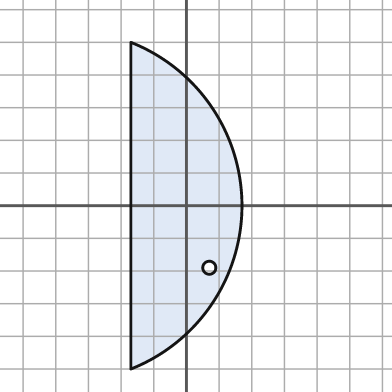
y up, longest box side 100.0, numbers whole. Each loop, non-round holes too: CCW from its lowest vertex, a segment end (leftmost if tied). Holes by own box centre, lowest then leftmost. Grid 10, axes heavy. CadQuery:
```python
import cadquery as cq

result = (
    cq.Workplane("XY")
    .moveTo(-17.0, -50.0)
    .threePointArc((17.0, 0.0), (-17.0, 50.0))
    .close()
    .moveTo(7.0, -19.0)
    .circle(2.0)
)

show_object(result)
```